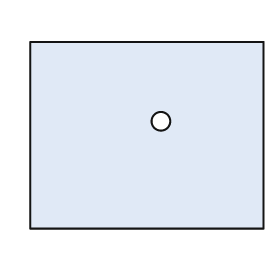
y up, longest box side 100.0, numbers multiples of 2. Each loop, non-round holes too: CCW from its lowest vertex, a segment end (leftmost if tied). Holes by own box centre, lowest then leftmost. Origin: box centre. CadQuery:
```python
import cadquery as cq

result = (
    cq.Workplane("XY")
    .moveTo(-50.0, -40.0)
    .lineTo(50.0, -40.0)
    .lineTo(50.0, 40.0)
    .lineTo(-50.0, 40.0)
    .close()
    .moveTo(6.0, 6.0)
    .circle(4.0)
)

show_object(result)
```